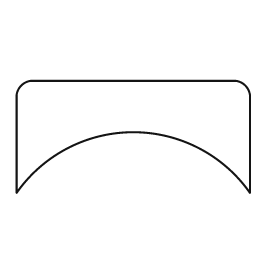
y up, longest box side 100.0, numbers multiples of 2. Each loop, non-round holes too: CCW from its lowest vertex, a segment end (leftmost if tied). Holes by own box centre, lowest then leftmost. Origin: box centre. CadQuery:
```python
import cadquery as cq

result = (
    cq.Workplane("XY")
    .moveTo(-50.0, -24.0)
    .threePointArc((0.0, 2.0), (50.0, -24.0))
    .lineTo(50.0, 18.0)
    .threePointArc((48.0, 22.0), (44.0, 24.0))
    .lineTo(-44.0, 24.0)
    .threePointArc((-48.0, 22.0), (-50.0, 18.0))
    .close()
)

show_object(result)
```